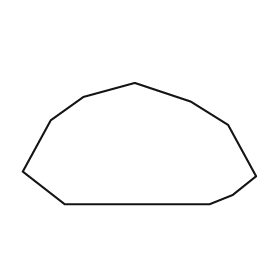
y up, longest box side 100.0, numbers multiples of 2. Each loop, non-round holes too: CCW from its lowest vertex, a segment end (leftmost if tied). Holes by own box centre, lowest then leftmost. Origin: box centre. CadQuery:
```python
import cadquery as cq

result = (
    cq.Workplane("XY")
    .moveTo(-32.0, -26.0)
    .lineTo(30.0, -26.0)
    .lineTo(40.0, -22.0)
    .lineTo(50.0, -14.0)
    .lineTo(38.0, 8.0)
    .lineTo(22.0, 18.0)
    .lineTo(-2.0, 26.0)
    .lineTo(-24.0, 20.0)
    .lineTo(-38.0, 10.0)
    .lineTo(-50.0, -12.0)
    .close()
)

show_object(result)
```